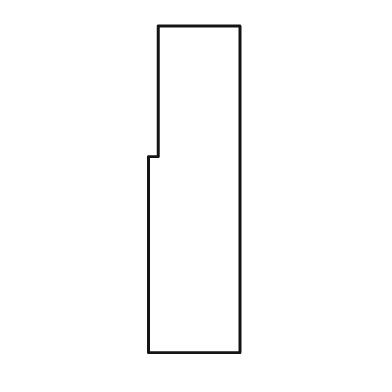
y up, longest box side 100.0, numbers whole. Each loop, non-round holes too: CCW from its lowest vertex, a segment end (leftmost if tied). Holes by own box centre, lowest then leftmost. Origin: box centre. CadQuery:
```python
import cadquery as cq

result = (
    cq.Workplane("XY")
    .moveTo(-14.0, -50.0)
    .lineTo(14.0, -50.0)
    .lineTo(14.0, 50.0)
    .lineTo(-11.0, 50.0)
    .lineTo(-11.0, 10.0)
    .lineTo(-14.0, 10.0)
    .close()
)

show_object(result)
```